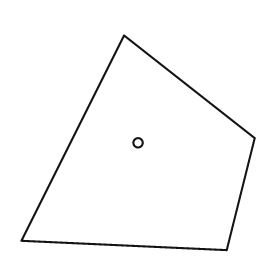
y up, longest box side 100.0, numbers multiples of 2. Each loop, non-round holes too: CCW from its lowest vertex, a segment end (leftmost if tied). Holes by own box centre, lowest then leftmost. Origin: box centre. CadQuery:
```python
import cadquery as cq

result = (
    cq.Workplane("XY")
    .moveTo(38.0, -46.0)
    .lineTo(50.0, 2.0)
    .lineTo(-6.0, 46.0)
    .lineTo(-50.0, -42.0)
    .close()
    .moveTo(0.0, 0.0)
    .circle(2.0)
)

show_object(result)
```